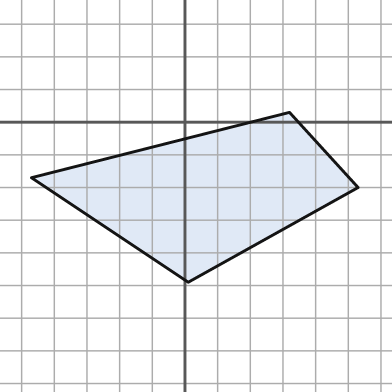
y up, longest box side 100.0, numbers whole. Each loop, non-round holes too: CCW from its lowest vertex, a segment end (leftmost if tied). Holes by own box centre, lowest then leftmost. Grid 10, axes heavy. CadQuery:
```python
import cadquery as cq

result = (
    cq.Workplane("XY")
    .moveTo(1.0, -49.0)
    .lineTo(53.0, -20.0)
    .lineTo(32.0, 3.0)
    .lineTo(-47.0, -17.0)
    .close()
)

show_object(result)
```